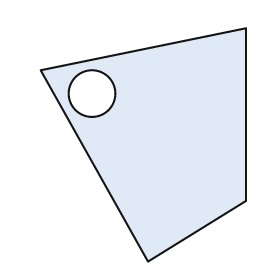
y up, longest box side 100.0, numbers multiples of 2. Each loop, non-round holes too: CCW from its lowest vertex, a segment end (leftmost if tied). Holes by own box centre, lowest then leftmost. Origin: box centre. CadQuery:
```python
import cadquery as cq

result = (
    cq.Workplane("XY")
    .moveTo(2.0, -50.0)
    .lineTo(44.0, -24.0)
    .lineTo(44.0, 50.0)
    .lineTo(-44.0, 32.0)
    .close()
    .moveTo(-22.0, 22.0)
    .circle(10.0)
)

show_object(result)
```